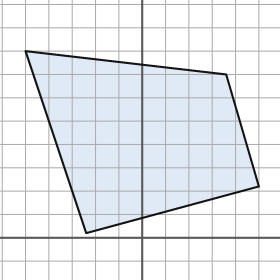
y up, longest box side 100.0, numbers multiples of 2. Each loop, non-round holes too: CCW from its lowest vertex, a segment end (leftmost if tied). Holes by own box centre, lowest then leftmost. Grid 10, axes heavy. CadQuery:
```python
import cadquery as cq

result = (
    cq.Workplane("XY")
    .moveTo(-24.0, 2.0)
    .lineTo(50.0, 22.0)
    .lineTo(36.0, 70.0)
    .lineTo(-50.0, 80.0)
    .close()
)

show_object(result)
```